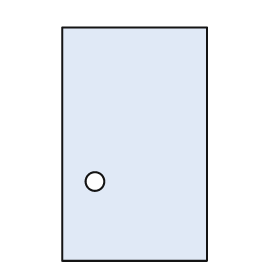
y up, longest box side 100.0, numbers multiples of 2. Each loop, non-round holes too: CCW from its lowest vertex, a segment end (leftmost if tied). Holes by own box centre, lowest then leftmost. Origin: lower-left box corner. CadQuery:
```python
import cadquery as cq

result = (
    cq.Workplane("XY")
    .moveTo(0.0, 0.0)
    .lineTo(62.0, 0.0)
    .lineTo(62.0, 100.0)
    .lineTo(0.0, 100.0)
    .close()
    .moveTo(14.0, 34.0)
    .circle(4.0)
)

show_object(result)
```